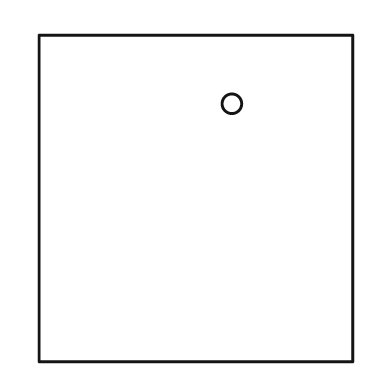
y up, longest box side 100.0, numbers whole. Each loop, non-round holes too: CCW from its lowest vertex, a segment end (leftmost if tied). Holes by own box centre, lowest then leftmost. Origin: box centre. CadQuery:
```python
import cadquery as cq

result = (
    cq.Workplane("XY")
    .moveTo(-48.0, -50.0)
    .lineTo(48.0, -50.0)
    .lineTo(48.0, 50.0)
    .lineTo(-48.0, 50.0)
    .close()
    .moveTo(11.0, 29.0)
    .circle(3.0)
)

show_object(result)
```